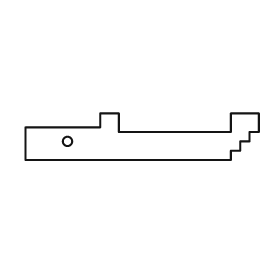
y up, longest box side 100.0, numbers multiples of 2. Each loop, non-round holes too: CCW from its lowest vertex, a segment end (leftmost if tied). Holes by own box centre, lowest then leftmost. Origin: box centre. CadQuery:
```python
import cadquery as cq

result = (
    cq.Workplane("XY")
    .moveTo(-50.0, -10.0)
    .lineTo(38.0, -10.0)
    .lineTo(38.0, -6.0)
    .lineTo(42.0, -6.0)
    .lineTo(42.0, -2.0)
    .lineTo(46.0, -2.0)
    .lineTo(46.0, 2.0)
    .lineTo(50.0, 2.0)
    .lineTo(50.0, 10.0)
    .lineTo(38.0, 10.0)
    .lineTo(38.0, 2.0)
    .lineTo(-10.0, 2.0)
    .lineTo(-10.0, 10.0)
    .lineTo(-18.0, 10.0)
    .lineTo(-18.0, 4.0)
    .lineTo(-50.0, 4.0)
    .close()
    .moveTo(-32.0, -2.0)
    .circle(2.0)
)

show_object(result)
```